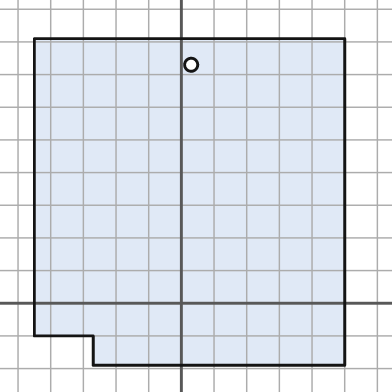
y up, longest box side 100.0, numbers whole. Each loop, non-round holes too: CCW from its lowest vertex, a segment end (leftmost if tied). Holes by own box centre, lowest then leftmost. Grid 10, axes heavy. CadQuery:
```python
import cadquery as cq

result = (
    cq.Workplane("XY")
    .moveTo(-27.0, -19.0)
    .lineTo(50.0, -19.0)
    .lineTo(50.0, 81.0)
    .lineTo(-45.0, 81.0)
    .lineTo(-45.0, -10.0)
    .lineTo(-27.0, -10.0)
    .close()
    .moveTo(3.0, 73.0)
    .circle(2.0)
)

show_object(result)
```